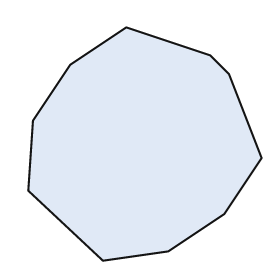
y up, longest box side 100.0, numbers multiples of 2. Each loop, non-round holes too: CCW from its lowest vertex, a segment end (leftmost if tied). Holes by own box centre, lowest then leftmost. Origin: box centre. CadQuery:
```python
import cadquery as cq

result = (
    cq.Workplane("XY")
    .moveTo(-18.0, -50.0)
    .lineTo(10.0, -46.0)
    .lineTo(34.0, -30.0)
    .lineTo(50.0, -6.0)
    .lineTo(36.0, 30.0)
    .lineTo(28.0, 38.0)
    .lineTo(-8.0, 50.0)
    .lineTo(-32.0, 34.0)
    .lineTo(-48.0, 10.0)
    .lineTo(-50.0, -20.0)
    .close()
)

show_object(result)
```